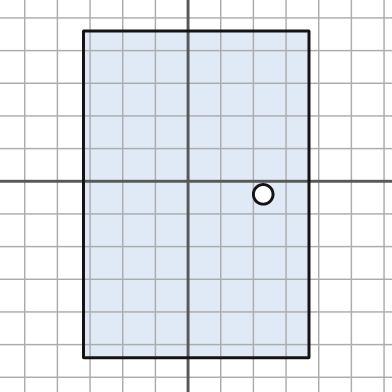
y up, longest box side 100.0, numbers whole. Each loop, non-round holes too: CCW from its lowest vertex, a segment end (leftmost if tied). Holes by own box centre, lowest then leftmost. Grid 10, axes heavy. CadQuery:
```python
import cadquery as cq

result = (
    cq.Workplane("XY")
    .moveTo(-32.0, -54.0)
    .lineTo(37.0, -54.0)
    .lineTo(37.0, 46.0)
    .lineTo(-32.0, 46.0)
    .close()
    .moveTo(23.0, -4.0)
    .circle(3.0)
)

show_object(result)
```